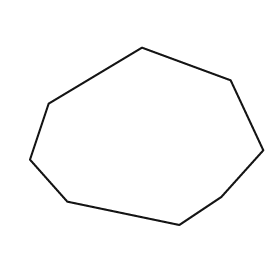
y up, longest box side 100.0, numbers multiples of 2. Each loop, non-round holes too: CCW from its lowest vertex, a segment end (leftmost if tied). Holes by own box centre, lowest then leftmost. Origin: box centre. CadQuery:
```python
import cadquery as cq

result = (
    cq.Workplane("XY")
    .moveTo(14.0, -38.0)
    .lineTo(32.0, -26.0)
    .lineTo(50.0, -6.0)
    .lineTo(36.0, 24.0)
    .lineTo(-2.0, 38.0)
    .lineTo(-42.0, 14.0)
    .lineTo(-50.0, -10.0)
    .lineTo(-34.0, -28.0)
    .close()
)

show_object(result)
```